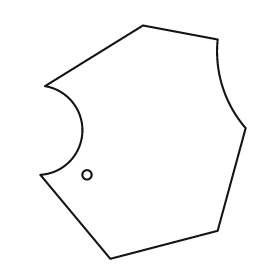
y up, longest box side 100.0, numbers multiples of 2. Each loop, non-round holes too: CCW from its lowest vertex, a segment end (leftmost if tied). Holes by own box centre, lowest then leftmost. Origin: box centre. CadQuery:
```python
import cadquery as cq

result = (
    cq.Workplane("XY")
    .moveTo(-14.0, -50.0)
    .lineTo(32.0, -38.0)
    .lineTo(44.0, 6.0)
    .threePointArc((34.0, 24.0), (32.0, 44.0))
    .lineTo(0.0, 50.0)
    .lineTo(-42.0, 24.0)
    .threePointArc((-26.0, 4.0), (-44.0, -14.0))
    .close()
    .moveTo(-24.0, -14.0)
    .circle(2.0)
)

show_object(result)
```